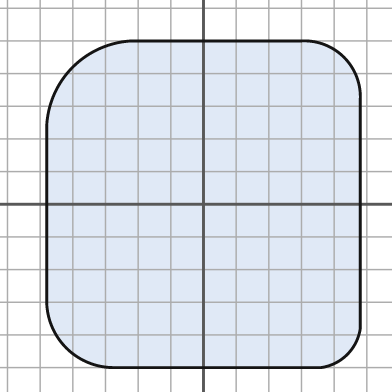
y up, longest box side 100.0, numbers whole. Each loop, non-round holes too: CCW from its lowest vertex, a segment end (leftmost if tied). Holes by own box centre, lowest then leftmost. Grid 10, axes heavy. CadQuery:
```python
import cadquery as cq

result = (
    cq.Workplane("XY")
    .moveTo(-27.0, -50.0)
    .lineTo(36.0, -50.0)
    .threePointArc((44.0, -46.0), (48.0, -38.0))
    .lineTo(48.0, 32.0)
    .threePointArc((43.0, 45.0), (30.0, 50.0))
    .lineTo(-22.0, 50.0)
    .threePointArc((-40.0, 42.0), (-48.0, 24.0))
    .lineTo(-48.0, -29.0)
    .threePointArc((-42.0, -44.0), (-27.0, -50.0))
    .close()
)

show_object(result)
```